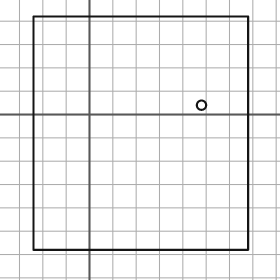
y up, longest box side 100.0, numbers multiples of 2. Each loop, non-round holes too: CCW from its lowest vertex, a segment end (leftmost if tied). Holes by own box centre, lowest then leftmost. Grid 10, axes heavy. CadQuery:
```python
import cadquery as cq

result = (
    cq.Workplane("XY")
    .moveTo(-24.0, -58.0)
    .lineTo(68.0, -58.0)
    .lineTo(68.0, 42.0)
    .lineTo(-24.0, 42.0)
    .close()
    .moveTo(48.0, 4.0)
    .circle(2.0)
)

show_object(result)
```